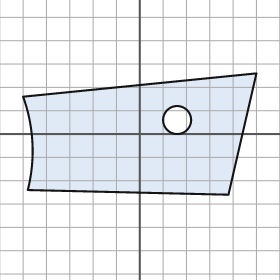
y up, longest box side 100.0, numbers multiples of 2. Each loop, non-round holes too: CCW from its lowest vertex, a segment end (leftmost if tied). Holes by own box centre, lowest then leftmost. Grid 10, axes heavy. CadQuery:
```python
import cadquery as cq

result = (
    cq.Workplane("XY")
    .moveTo(38.0, -26.0)
    .lineTo(50.0, 26.0)
    .lineTo(-50.0, 16.0)
    .threePointArc((-46.0, -4.0), (-48.0, -24.0))
    .close()
    .moveTo(16.0, 6.0)
    .circle(6.0)
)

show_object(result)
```